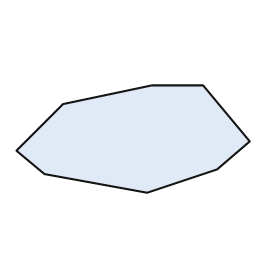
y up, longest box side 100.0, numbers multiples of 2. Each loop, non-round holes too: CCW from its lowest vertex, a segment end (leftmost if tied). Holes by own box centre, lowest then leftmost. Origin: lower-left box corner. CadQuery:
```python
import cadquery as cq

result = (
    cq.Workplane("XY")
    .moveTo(56.0, 0.0)
    .lineTo(86.0, 10.0)
    .lineTo(100.0, 22.0)
    .lineTo(80.0, 46.0)
    .lineTo(58.0, 46.0)
    .lineTo(20.0, 38.0)
    .lineTo(0.0, 18.0)
    .lineTo(12.0, 8.0)
    .close()
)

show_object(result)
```